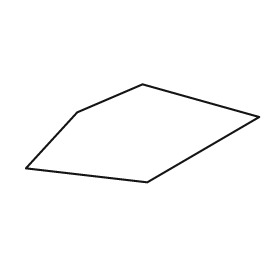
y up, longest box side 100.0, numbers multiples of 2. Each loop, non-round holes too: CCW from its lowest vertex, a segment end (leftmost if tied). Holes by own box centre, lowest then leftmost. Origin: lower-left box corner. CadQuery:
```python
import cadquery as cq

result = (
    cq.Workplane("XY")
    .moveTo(52.0, 0.0)
    .lineTo(100.0, 28.0)
    .lineTo(50.0, 42.0)
    .lineTo(22.0, 30.0)
    .lineTo(0.0, 6.0)
    .close()
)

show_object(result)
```